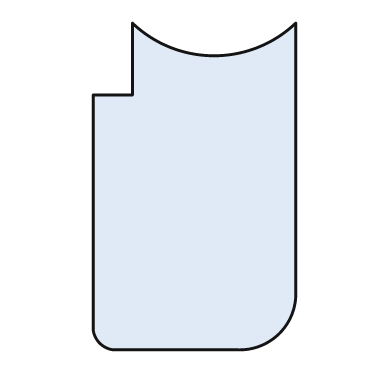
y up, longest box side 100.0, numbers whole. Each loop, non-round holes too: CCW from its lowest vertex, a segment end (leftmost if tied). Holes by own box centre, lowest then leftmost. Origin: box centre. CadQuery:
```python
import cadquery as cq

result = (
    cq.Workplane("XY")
    .moveTo(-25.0, -50.0)
    .lineTo(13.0, -50.0)
    .threePointArc((26.0, -45.0), (31.0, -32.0))
    .lineTo(31.0, 50.0)
    .threePointArc((6.0, 40.0), (-19.0, 50.0))
    .lineTo(-19.0, 28.0)
    .lineTo(-31.0, 28.0)
    .lineTo(-31.0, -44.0)
    .threePointArc((-29.0, -48.0), (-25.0, -50.0))
    .close()
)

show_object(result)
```